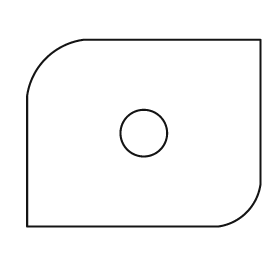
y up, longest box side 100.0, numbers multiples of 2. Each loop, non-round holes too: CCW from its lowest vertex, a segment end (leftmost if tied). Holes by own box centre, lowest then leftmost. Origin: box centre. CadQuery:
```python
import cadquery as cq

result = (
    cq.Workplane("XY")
    .moveTo(-50.0, -40.0)
    .lineTo(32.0, -40.0)
    .threePointArc((44.0, -34.0), (50.0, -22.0))
    .lineTo(50.0, 40.0)
    .lineTo(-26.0, 40.0)
    .threePointArc((-42.0, 32.0), (-50.0, 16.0))
    .close()
    .moveTo(0.0, 0.0)
    .circle(10.0)
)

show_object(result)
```